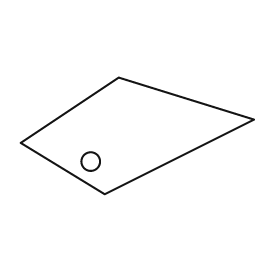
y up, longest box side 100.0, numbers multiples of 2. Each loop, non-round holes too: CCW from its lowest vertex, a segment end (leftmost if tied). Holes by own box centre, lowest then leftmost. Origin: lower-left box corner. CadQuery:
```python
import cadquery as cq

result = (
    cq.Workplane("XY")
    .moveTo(36.0, 0.0)
    .lineTo(100.0, 32.0)
    .lineTo(42.0, 50.0)
    .lineTo(0.0, 22.0)
    .close()
    .moveTo(30.0, 14.0)
    .circle(4.0)
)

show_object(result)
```